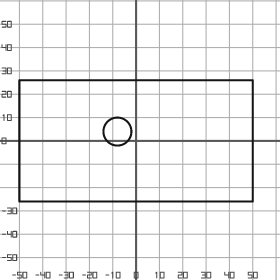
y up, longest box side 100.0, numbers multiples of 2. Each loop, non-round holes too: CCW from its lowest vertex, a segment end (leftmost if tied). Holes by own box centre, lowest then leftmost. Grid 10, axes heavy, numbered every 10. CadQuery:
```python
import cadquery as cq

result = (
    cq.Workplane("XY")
    .moveTo(-50.0, -26.0)
    .lineTo(50.0, -26.0)
    .lineTo(50.0, 26.0)
    .lineTo(-50.0, 26.0)
    .close()
    .moveTo(-8.0, 4.0)
    .circle(6.0)
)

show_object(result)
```